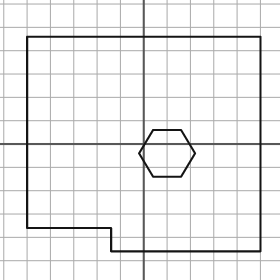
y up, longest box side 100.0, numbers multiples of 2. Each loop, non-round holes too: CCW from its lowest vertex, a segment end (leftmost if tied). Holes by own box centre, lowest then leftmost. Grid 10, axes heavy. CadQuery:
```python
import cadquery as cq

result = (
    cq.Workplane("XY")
    .moveTo(-14.0, -46.0)
    .lineTo(50.0, -46.0)
    .lineTo(50.0, 46.0)
    .lineTo(-50.0, 46.0)
    .lineTo(-50.0, -36.0)
    .lineTo(-14.0, -36.0)
    .close()
    .moveTo(4.0, -14.0)
    .lineTo(16.0, -14.0)
    .lineTo(22.0, -4.0)
    .lineTo(16.0, 6.0)
    .lineTo(4.0, 6.0)
    .lineTo(-2.0, -4.0)
    .close()
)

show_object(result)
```